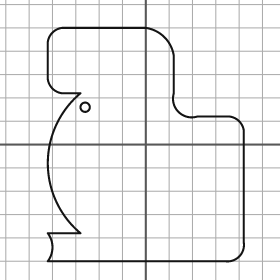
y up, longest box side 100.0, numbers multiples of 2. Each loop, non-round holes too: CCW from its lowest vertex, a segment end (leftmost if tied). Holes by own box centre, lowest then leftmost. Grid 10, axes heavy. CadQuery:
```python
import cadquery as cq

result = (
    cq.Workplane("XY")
    .moveTo(-42.0, -50.0)
    .lineTo(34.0, -50.0)
    .threePointArc((40.0, -48.0), (42.0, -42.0))
    .lineTo(42.0, 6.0)
    .threePointArc((40.0, 10.0), (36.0, 12.0))
    .lineTo(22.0, 12.0)
    .threePointArc((14.0, 14.0), (12.0, 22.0))
    .lineTo(12.0, 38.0)
    .threePointArc((8.0, 46.0), (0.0, 50.0))
    .lineTo(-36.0, 50.0)
    .threePointArc((-40.0, 48.0), (-42.0, 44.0))
    .lineTo(-42.0, 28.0)
    .threePointArc((-40.0, 24.0), (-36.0, 22.0))
    .lineTo(-28.0, 22.0)
    .threePointArc((-42.0, -8.0), (-28.0, -38.0))
    .lineTo(-42.0, -38.0)
    .threePointArc((-40.0, -44.0), (-42.0, -50.0))
    .close()
    .moveTo(-26.0, 16.0)
    .circle(2.0)
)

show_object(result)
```